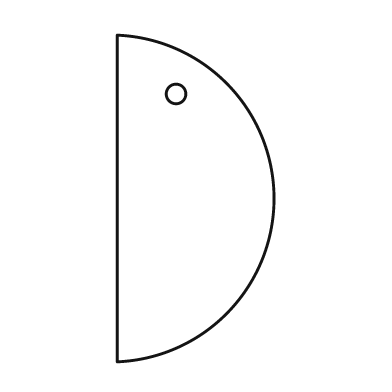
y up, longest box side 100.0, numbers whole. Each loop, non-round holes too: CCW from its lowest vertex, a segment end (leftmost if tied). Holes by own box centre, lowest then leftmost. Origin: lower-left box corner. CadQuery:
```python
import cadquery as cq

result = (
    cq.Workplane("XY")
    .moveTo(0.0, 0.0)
    .threePointArc((48.0, 50.0), (0.0, 100.0))
    .close()
    .moveTo(18.0, 82.0)
    .circle(3.0)
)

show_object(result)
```